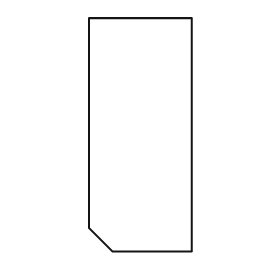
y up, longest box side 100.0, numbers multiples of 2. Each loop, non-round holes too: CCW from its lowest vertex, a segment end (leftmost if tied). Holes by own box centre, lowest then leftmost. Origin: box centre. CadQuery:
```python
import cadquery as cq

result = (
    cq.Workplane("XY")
    .moveTo(-12.0, -50.0)
    .lineTo(22.0, -50.0)
    .lineTo(22.0, 50.0)
    .lineTo(-22.0, 50.0)
    .lineTo(-22.0, -40.0)
    .close()
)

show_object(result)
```